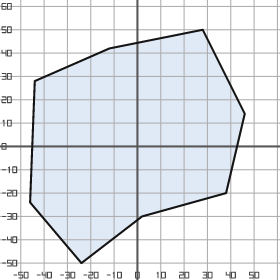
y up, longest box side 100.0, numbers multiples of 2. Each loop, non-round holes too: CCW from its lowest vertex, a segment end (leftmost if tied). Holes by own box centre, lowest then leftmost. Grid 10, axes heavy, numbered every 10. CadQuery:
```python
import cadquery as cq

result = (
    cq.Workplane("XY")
    .moveTo(-24.0, -50.0)
    .lineTo(2.0, -30.0)
    .lineTo(38.0, -20.0)
    .lineTo(46.0, 14.0)
    .lineTo(28.0, 50.0)
    .lineTo(-12.0, 42.0)
    .lineTo(-44.0, 28.0)
    .lineTo(-46.0, -24.0)
    .close()
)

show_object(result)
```